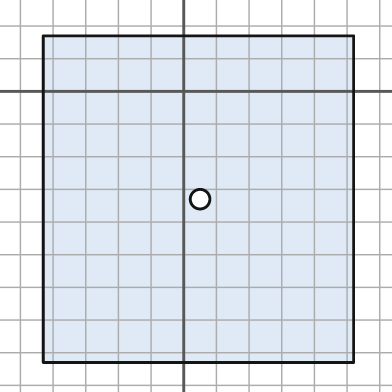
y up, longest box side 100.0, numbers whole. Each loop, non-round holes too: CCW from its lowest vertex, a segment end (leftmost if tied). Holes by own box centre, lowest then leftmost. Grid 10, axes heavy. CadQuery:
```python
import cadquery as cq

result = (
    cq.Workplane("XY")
    .moveTo(-43.0, -83.0)
    .lineTo(52.0, -83.0)
    .lineTo(52.0, 17.0)
    .lineTo(-43.0, 17.0)
    .close()
    .moveTo(5.0, -33.0)
    .circle(3.0)
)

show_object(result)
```